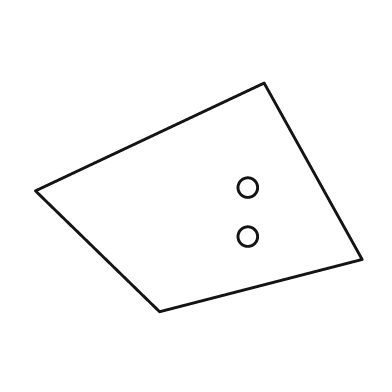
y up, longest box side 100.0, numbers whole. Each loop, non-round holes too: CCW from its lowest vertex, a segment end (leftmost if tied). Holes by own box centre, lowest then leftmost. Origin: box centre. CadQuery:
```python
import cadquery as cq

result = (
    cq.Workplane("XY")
    .moveTo(-12.0, -35.0)
    .lineTo(50.0, -19.0)
    .lineTo(20.0, 35.0)
    .lineTo(-50.0, 2.0)
    .close()
    .moveTo(15.0, -12.0)
    .circle(3.0)
    .moveTo(15.0, 3.0)
    .circle(3.0)
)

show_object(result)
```